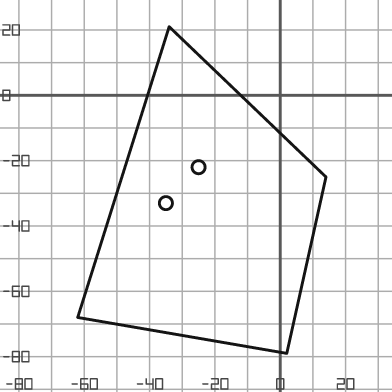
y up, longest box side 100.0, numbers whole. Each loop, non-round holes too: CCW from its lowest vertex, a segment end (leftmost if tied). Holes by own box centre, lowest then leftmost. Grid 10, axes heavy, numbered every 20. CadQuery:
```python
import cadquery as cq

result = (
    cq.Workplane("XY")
    .moveTo(2.0, -79.0)
    .lineTo(14.0, -25.0)
    .lineTo(-34.0, 21.0)
    .lineTo(-62.0, -68.0)
    .close()
    .moveTo(-35.0, -33.0)
    .circle(2.0)
    .moveTo(-25.0, -22.0)
    .circle(2.0)
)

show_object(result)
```